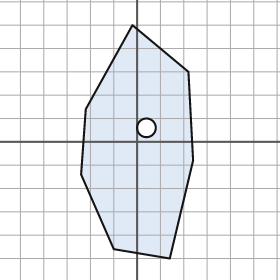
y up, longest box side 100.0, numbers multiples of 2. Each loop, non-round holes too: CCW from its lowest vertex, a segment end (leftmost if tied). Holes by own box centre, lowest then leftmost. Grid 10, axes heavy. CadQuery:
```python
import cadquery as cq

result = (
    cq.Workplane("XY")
    .moveTo(14.0, -50.0)
    .lineTo(24.0, -8.0)
    .lineTo(22.0, 30.0)
    .lineTo(-2.0, 50.0)
    .lineTo(-22.0, 14.0)
    .lineTo(-24.0, -14.0)
    .lineTo(-10.0, -46.0)
    .close()
    .moveTo(4.0, 6.0)
    .circle(4.0)
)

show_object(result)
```